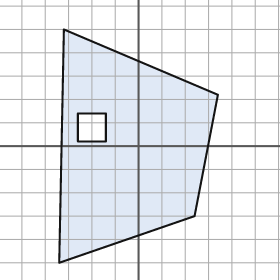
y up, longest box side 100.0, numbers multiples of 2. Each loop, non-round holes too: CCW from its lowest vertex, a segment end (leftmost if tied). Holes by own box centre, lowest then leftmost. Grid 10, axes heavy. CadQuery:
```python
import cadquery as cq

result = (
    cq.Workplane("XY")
    .moveTo(-34.0, -50.0)
    .lineTo(24.0, -30.0)
    .lineTo(34.0, 22.0)
    .lineTo(-32.0, 50.0)
    .close()
    .moveTo(-26.0, 2.0)
    .lineTo(-14.0, 2.0)
    .lineTo(-14.0, 14.0)
    .lineTo(-26.0, 14.0)
    .close()
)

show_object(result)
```